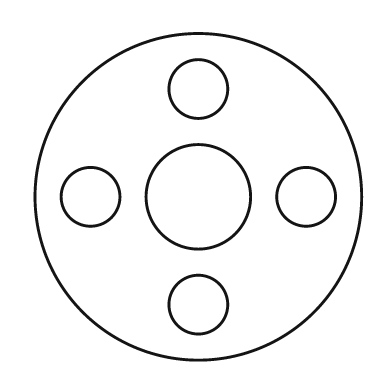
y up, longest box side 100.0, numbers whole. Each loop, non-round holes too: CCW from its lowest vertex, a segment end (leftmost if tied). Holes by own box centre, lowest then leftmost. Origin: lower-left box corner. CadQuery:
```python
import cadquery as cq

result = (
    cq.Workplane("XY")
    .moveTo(50.0, 50.0)
    .circle(50.0)
    .moveTo(50.0, 17.0)
    .circle(9.0)
    .moveTo(17.0, 50.0)
    .circle(9.0)
    .moveTo(50.0, 50.0)
    .circle(16.0)
    .moveTo(83.0, 50.0)
    .circle(9.0)
    .moveTo(50.0, 83.0)
    .circle(9.0)
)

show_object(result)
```